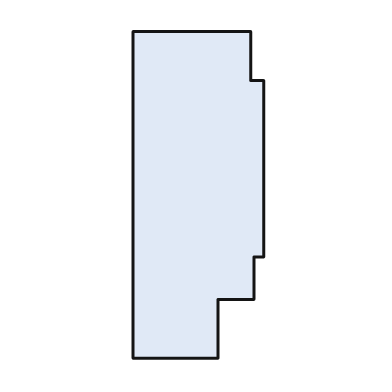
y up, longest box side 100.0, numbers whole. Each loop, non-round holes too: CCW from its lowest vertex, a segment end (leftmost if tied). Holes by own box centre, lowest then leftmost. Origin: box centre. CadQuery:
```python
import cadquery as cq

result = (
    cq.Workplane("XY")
    .moveTo(-20.0, -50.0)
    .lineTo(6.0, -50.0)
    .lineTo(6.0, -32.0)
    .lineTo(17.0, -32.0)
    .lineTo(17.0, -19.0)
    .lineTo(20.0, -19.0)
    .lineTo(20.0, 35.0)
    .lineTo(16.0, 35.0)
    .lineTo(16.0, 50.0)
    .lineTo(-20.0, 50.0)
    .close()
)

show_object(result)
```